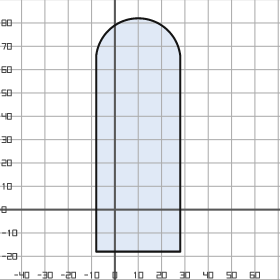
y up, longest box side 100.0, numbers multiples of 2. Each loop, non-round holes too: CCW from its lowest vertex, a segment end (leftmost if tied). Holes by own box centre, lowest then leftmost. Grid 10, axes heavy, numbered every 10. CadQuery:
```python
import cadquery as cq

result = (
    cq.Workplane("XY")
    .moveTo(-8.0, -18.0)
    .lineTo(28.0, -18.0)
    .lineTo(28.0, 66.0)
    .threePointArc((10.0, 82.0), (-8.0, 66.0))
    .close()
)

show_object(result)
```